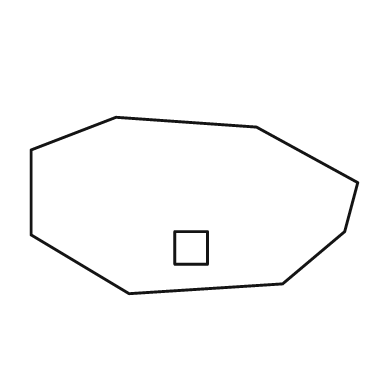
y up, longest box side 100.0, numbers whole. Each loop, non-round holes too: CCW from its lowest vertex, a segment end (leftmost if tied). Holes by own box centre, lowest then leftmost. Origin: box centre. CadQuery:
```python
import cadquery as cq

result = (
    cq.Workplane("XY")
    .moveTo(-20.0, -27.0)
    .lineTo(27.0, -24.0)
    .lineTo(46.0, -8.0)
    .lineTo(50.0, 7.0)
    .lineTo(19.0, 24.0)
    .lineTo(-24.0, 27.0)
    .lineTo(-50.0, 17.0)
    .lineTo(-50.0, -9.0)
    .close()
    .moveTo(-6.0, -18.0)
    .lineTo(4.0, -18.0)
    .lineTo(4.0, -8.0)
    .lineTo(-6.0, -8.0)
    .close()
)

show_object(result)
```